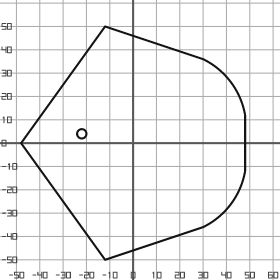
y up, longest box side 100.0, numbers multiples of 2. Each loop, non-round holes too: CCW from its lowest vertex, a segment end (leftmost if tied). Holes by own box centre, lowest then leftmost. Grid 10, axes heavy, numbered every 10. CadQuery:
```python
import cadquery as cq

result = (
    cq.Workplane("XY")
    .moveTo(-12.0, -50.0)
    .lineTo(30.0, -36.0)
    .threePointArc((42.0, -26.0), (48.0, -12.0))
    .lineTo(48.0, 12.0)
    .threePointArc((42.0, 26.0), (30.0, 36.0))
    .lineTo(-12.0, 50.0)
    .lineTo(-48.0, 0.0)
    .close()
    .moveTo(-22.0, 4.0)
    .circle(2.0)
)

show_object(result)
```